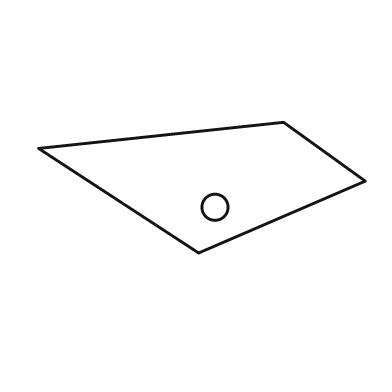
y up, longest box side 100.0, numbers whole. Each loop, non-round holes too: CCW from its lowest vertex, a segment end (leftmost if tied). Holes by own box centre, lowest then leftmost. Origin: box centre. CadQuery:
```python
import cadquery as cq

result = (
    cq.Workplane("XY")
    .moveTo(-1.0, -20.0)
    .lineTo(50.0, 2.0)
    .lineTo(25.0, 20.0)
    .lineTo(-50.0, 12.0)
    .close()
    .moveTo(4.0, -6.0)
    .circle(4.0)
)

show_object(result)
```